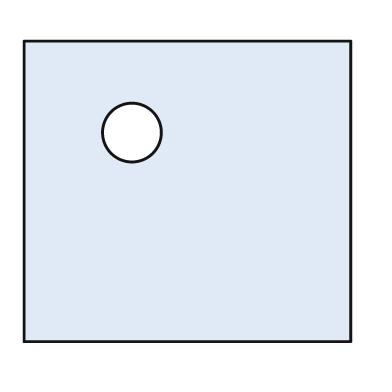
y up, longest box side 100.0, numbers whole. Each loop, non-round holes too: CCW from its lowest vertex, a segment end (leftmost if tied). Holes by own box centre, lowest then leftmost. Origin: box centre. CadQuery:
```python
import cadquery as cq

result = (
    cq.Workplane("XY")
    .moveTo(-50.0, -46.0)
    .lineTo(50.0, -46.0)
    .lineTo(50.0, 46.0)
    .lineTo(-50.0, 46.0)
    .close()
    .moveTo(-17.0, 18.0)
    .circle(9.0)
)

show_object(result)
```